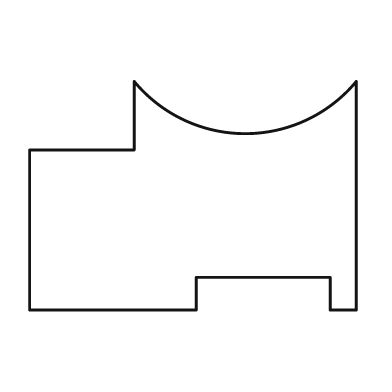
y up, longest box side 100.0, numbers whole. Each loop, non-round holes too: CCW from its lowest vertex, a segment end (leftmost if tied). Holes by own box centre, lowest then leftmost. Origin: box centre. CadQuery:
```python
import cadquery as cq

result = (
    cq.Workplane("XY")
    .moveTo(-50.0, -35.0)
    .lineTo(1.0, -35.0)
    .lineTo(1.0, -25.0)
    .lineTo(42.0, -25.0)
    .lineTo(42.0, -35.0)
    .lineTo(50.0, -35.0)
    .lineTo(50.0, 35.0)
    .threePointArc((16.0, 19.0), (-18.0, 35.0))
    .lineTo(-18.0, 14.0)
    .lineTo(-50.0, 14.0)
    .close()
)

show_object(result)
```